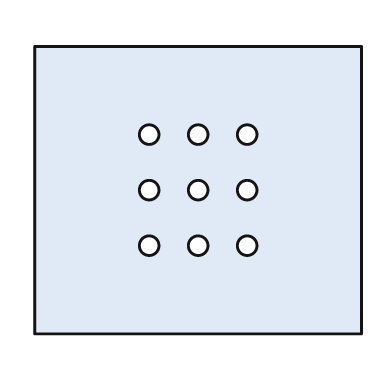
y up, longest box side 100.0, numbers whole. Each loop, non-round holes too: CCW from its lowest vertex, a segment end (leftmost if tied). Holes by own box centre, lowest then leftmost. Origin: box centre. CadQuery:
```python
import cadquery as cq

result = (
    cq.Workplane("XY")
    .moveTo(-50.0, -44.0)
    .lineTo(50.0, -44.0)
    .lineTo(50.0, 44.0)
    .lineTo(-50.0, 44.0)
    .close()
    .moveTo(-15.0, -17.0)
    .circle(3.0)
    .moveTo(0.0, -17.0)
    .circle(3.0)
    .moveTo(15.0, -17.0)
    .circle(3.0)
    .moveTo(-15.0, 0.0)
    .circle(3.0)
    .moveTo(0.0, 0.0)
    .circle(3.0)
    .moveTo(15.0, 0.0)
    .circle(3.0)
    .moveTo(-15.0, 17.0)
    .circle(3.0)
    .moveTo(0.0, 17.0)
    .circle(3.0)
    .moveTo(15.0, 17.0)
    .circle(3.0)
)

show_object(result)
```